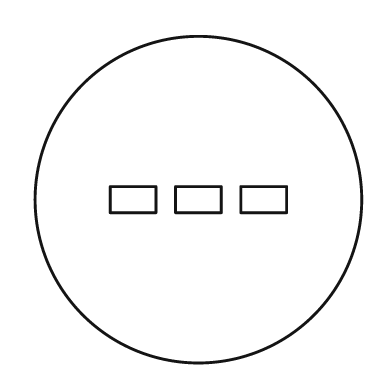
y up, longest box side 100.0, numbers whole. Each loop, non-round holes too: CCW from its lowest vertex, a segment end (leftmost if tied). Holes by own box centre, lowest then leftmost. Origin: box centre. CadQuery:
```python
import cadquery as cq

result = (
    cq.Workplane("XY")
    .moveTo(0.0, 0.0)
    .circle(50.0)
    .moveTo(-27.0, -4.0)
    .lineTo(-13.0, -4.0)
    .lineTo(-13.0, 4.0)
    .lineTo(-27.0, 4.0)
    .close()
    .moveTo(-7.0, -4.0)
    .lineTo(7.0, -4.0)
    .lineTo(7.0, 4.0)
    .lineTo(-7.0, 4.0)
    .close()
    .moveTo(13.0, -4.0)
    .lineTo(27.0, -4.0)
    .lineTo(27.0, 4.0)
    .lineTo(13.0, 4.0)
    .close()
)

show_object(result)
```